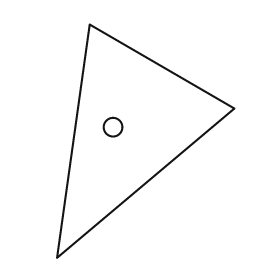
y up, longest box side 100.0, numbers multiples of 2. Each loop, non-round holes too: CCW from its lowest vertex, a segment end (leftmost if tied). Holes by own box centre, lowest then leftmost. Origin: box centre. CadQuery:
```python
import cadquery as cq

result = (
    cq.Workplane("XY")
    .moveTo(-38.0, -50.0)
    .lineTo(38.0, 14.0)
    .lineTo(-24.0, 50.0)
    .close()
    .moveTo(-14.0, 6.0)
    .circle(4.0)
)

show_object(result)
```